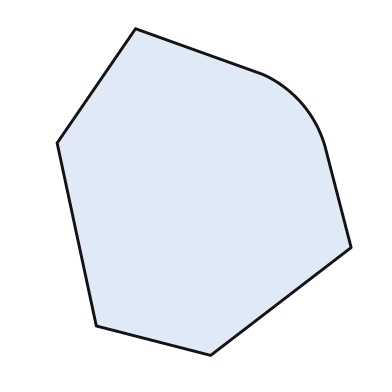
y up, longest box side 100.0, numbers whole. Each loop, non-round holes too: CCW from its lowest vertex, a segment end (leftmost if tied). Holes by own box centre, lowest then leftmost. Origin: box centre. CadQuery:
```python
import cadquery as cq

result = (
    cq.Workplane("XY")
    .moveTo(2.0, -50.0)
    .lineTo(45.0, -17.0)
    .lineTo(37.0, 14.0)
    .threePointArc((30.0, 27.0), (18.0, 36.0))
    .lineTo(-21.0, 50.0)
    .lineTo(-45.0, 15.0)
    .lineTo(-33.0, -41.0)
    .close()
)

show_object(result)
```